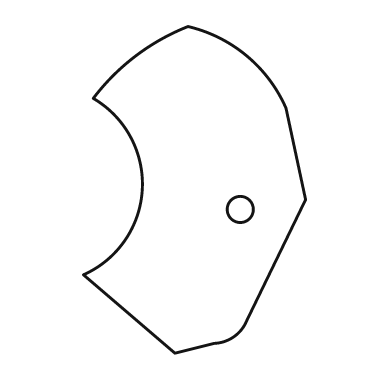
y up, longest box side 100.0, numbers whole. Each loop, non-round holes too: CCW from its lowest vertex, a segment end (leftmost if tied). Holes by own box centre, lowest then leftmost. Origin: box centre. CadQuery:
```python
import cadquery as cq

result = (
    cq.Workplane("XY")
    .moveTo(-6.0, -50.0)
    .lineTo(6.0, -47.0)
    .threePointArc((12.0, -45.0), (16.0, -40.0))
    .lineTo(34.0, -3.0)
    .lineTo(28.0, 25.0)
    .threePointArc((16.0, 41.0), (-2.0, 50.0))
    .threePointArc((-18.0, 41.0), (-31.0, 28.0))
    .threePointArc((-16.0, 0.0), (-34.0, -26.0))
    .close()
    .moveTo(14.0, -6.0)
    .circle(4.0)
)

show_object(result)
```